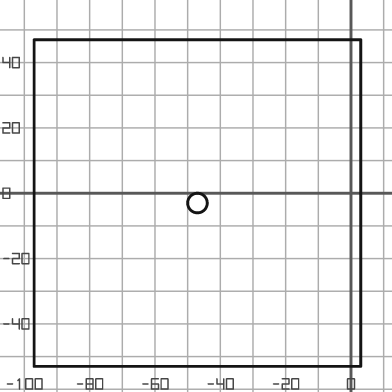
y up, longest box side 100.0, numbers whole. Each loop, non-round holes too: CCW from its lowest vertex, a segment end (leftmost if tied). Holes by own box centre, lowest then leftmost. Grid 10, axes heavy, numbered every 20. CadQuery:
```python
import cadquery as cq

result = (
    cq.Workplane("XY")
    .moveTo(-97.0, -53.0)
    .lineTo(3.0, -53.0)
    .lineTo(3.0, 47.0)
    .lineTo(-97.0, 47.0)
    .close()
    .moveTo(-47.0, -3.0)
    .circle(3.0)
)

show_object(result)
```